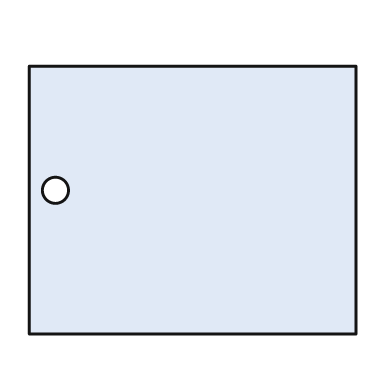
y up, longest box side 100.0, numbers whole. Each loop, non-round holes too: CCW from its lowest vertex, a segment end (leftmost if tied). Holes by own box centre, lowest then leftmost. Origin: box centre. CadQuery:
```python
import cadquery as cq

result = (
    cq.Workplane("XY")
    .moveTo(-50.0, -41.0)
    .lineTo(50.0, -41.0)
    .lineTo(50.0, 41.0)
    .lineTo(-50.0, 41.0)
    .close()
    .moveTo(-42.0, 3.0)
    .circle(4.0)
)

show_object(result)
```